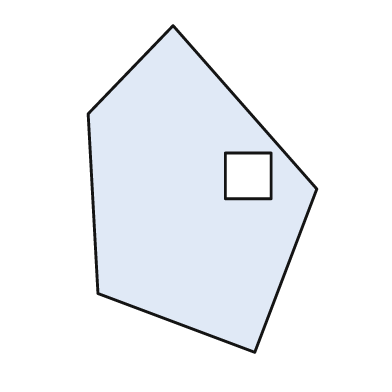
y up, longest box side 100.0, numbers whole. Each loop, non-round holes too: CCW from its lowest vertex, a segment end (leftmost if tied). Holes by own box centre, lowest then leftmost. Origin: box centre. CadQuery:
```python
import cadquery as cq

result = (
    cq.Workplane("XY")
    .moveTo(16.0, -50.0)
    .lineTo(35.0, 0.0)
    .lineTo(-9.0, 50.0)
    .lineTo(-35.0, 23.0)
    .lineTo(-32.0, -32.0)
    .close()
    .moveTo(7.0, -3.0)
    .lineTo(21.0, -3.0)
    .lineTo(21.0, 11.0)
    .lineTo(7.0, 11.0)
    .close()
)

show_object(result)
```